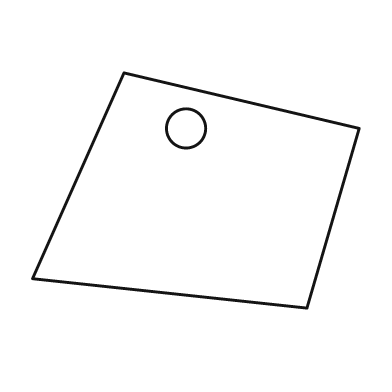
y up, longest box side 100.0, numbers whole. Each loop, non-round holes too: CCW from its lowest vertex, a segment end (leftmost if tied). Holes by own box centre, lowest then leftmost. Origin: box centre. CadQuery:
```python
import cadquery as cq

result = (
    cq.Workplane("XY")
    .moveTo(34.0, -36.0)
    .lineTo(50.0, 19.0)
    .lineTo(-22.0, 36.0)
    .lineTo(-50.0, -27.0)
    .close()
    .moveTo(-3.0, 19.0)
    .circle(6.0)
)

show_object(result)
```